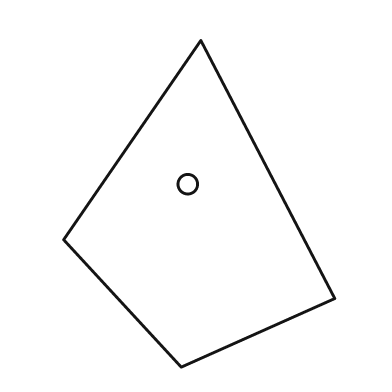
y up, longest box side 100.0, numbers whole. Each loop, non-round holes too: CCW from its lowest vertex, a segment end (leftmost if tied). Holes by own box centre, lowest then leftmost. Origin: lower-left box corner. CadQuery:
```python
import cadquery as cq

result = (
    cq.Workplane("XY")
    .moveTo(36.0, 0.0)
    .lineTo(83.0, 21.0)
    .lineTo(42.0, 100.0)
    .lineTo(0.0, 39.0)
    .close()
    .moveTo(38.0, 56.0)
    .circle(3.0)
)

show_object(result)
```